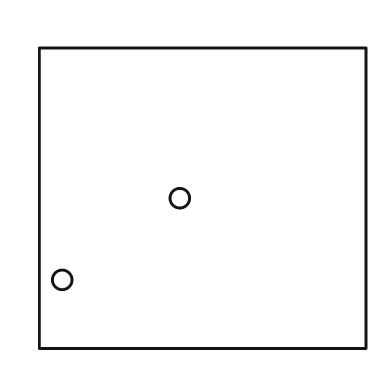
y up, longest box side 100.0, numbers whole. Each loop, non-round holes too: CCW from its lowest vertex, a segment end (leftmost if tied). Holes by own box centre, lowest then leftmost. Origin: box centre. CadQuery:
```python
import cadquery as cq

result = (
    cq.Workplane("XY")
    .moveTo(-50.0, -46.0)
    .lineTo(50.0, -46.0)
    .lineTo(50.0, 46.0)
    .lineTo(-50.0, 46.0)
    .close()
    .moveTo(-43.0, -25.0)
    .circle(3.0)
    .moveTo(-7.0, 0.0)
    .circle(3.0)
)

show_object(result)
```